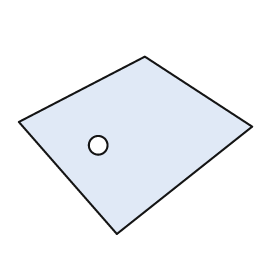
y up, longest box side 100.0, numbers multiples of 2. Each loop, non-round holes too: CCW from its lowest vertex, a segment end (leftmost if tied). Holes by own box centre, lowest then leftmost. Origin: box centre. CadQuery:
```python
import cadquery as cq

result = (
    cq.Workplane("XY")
    .moveTo(-8.0, -38.0)
    .lineTo(50.0, 8.0)
    .lineTo(4.0, 38.0)
    .lineTo(-50.0, 10.0)
    .close()
    .moveTo(-16.0, 0.0)
    .circle(4.0)
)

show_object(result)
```